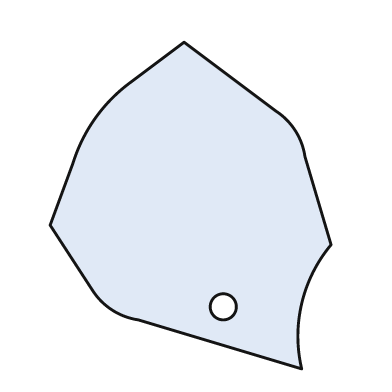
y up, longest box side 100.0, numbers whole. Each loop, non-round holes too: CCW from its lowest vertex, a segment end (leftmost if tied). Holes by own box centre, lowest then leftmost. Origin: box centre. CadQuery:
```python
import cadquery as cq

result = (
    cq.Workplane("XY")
    .moveTo(34.0, -50.0)
    .threePointArc((34.0, -30.0), (43.0, -12.0))
    .lineTo(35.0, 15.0)
    .threePointArc((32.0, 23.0), (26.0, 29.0))
    .lineTo(-2.0, 50.0)
    .lineTo(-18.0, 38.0)
    .threePointArc((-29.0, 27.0), (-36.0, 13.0))
    .lineTo(-43.0, -6.0)
    .lineTo(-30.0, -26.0)
    .threePointArc((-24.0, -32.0), (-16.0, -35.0))
    .close()
    .moveTo(10.0, -31.0)
    .circle(4.0)
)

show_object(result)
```